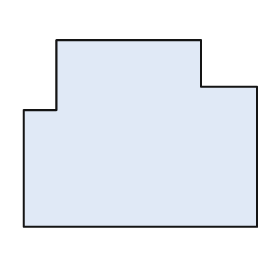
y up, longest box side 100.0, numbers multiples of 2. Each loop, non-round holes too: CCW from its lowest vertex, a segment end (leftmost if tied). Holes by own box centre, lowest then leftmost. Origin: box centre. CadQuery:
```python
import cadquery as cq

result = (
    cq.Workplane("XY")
    .moveTo(-50.0, -40.0)
    .lineTo(50.0, -40.0)
    .lineTo(50.0, 20.0)
    .lineTo(26.0, 20.0)
    .lineTo(26.0, 40.0)
    .lineTo(-36.0, 40.0)
    .lineTo(-36.0, 10.0)
    .lineTo(-50.0, 10.0)
    .close()
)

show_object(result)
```